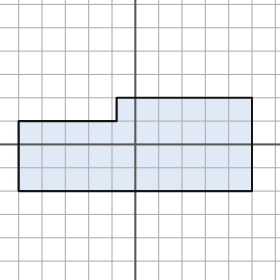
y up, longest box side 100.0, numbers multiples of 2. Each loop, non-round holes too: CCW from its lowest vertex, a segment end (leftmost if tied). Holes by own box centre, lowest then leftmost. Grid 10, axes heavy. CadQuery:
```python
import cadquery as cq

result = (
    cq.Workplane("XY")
    .moveTo(-50.0, -20.0)
    .lineTo(50.0, -20.0)
    .lineTo(50.0, 20.0)
    .lineTo(-8.0, 20.0)
    .lineTo(-8.0, 10.0)
    .lineTo(-50.0, 10.0)
    .close()
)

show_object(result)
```